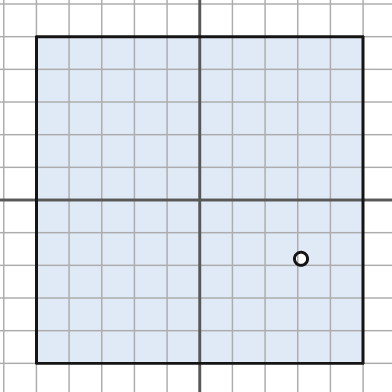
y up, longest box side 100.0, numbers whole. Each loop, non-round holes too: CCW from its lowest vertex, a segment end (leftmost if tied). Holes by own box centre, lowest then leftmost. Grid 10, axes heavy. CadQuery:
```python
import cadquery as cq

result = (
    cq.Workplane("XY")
    .moveTo(-50.0, -50.0)
    .lineTo(50.0, -50.0)
    .lineTo(50.0, 50.0)
    .lineTo(-50.0, 50.0)
    .close()
    .moveTo(31.0, -18.0)
    .circle(2.0)
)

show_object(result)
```